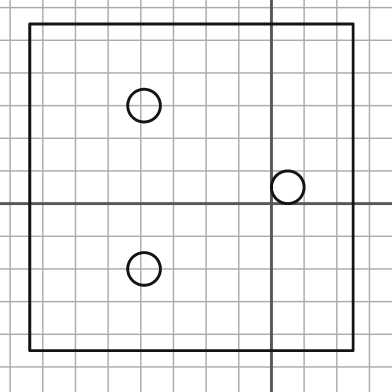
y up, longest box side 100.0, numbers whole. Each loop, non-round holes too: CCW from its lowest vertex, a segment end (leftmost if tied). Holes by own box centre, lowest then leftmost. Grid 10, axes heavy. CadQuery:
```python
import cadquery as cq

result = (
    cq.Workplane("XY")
    .moveTo(-74.0, -45.0)
    .lineTo(25.0, -45.0)
    .lineTo(25.0, 55.0)
    .lineTo(-74.0, 55.0)
    .close()
    .moveTo(-39.0, -20.0)
    .circle(5.0)
    .moveTo(5.0, 5.0)
    .circle(5.0)
    .moveTo(-39.0, 30.0)
    .circle(5.0)
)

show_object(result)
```